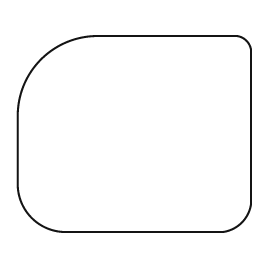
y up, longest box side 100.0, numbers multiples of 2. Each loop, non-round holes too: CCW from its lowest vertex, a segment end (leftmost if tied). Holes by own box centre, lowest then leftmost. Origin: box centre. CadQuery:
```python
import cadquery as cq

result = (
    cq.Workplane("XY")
    .moveTo(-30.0, -42.0)
    .lineTo(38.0, -42.0)
    .threePointArc((46.0, -38.0), (50.0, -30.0))
    .lineTo(50.0, 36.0)
    .threePointArc((48.0, 40.0), (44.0, 42.0))
    .lineTo(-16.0, 42.0)
    .threePointArc((-40.0, 32.0), (-50.0, 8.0))
    .lineTo(-50.0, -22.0)
    .threePointArc((-44.0, -36.0), (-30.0, -42.0))
    .close()
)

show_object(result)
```